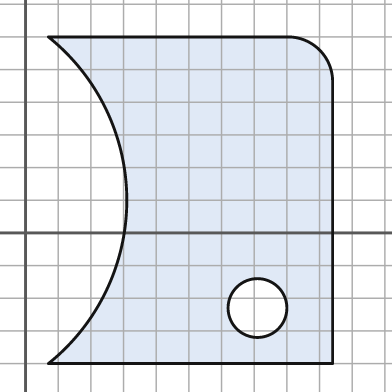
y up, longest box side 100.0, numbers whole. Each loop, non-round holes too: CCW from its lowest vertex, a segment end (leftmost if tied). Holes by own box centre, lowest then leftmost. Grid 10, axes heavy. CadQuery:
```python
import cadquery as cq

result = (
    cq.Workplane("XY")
    .moveTo(7.0, -40.0)
    .lineTo(94.0, -40.0)
    .lineTo(94.0, 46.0)
    .threePointArc((90.0, 56.0), (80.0, 60.0))
    .lineTo(7.0, 60.0)
    .threePointArc((31.0, 10.0), (7.0, -40.0))
    .close()
    .moveTo(71.0, -23.0)
    .circle(9.0)
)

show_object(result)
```